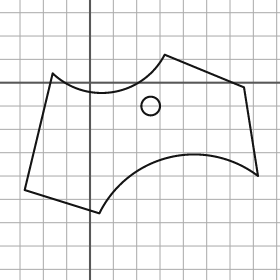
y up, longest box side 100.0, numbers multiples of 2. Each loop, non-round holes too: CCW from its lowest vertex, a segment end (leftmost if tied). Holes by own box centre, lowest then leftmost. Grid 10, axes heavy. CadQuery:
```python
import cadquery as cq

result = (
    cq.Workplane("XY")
    .moveTo(4.0, -56.0)
    .threePointArc((34.0, -32.0), (72.0, -40.0))
    .lineTo(66.0, -2.0)
    .lineTo(32.0, 12.0)
    .threePointArc((10.0, -4.0), (-16.0, 4.0))
    .lineTo(-28.0, -46.0)
    .close()
    .moveTo(26.0, -10.0)
    .circle(4.0)
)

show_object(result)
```